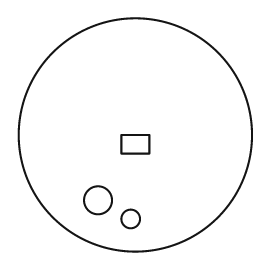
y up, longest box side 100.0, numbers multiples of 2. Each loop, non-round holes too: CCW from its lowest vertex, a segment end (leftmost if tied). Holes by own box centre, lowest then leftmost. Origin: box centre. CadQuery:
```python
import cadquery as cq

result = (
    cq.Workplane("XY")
    .moveTo(0.0, 0.0)
    .circle(50.0)
    .moveTo(-2.0, -36.0)
    .circle(4.0)
    .moveTo(-16.0, -28.0)
    .circle(6.0)
    .moveTo(-6.0, -8.0)
    .lineTo(6.0, -8.0)
    .lineTo(6.0, 0.0)
    .lineTo(-6.0, 0.0)
    .close()
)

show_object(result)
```